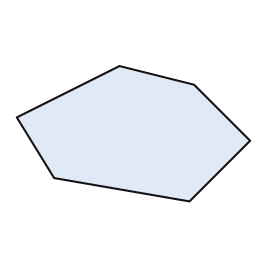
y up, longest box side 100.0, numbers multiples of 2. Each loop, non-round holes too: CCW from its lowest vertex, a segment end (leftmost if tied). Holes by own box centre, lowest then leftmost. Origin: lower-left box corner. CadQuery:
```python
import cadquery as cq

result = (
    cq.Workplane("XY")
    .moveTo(74.0, 0.0)
    .lineTo(100.0, 26.0)
    .lineTo(76.0, 50.0)
    .lineTo(44.0, 58.0)
    .lineTo(0.0, 36.0)
    .lineTo(16.0, 10.0)
    .close()
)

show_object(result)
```